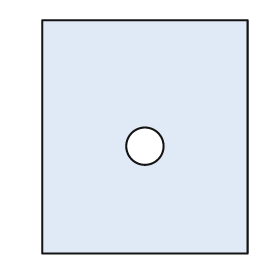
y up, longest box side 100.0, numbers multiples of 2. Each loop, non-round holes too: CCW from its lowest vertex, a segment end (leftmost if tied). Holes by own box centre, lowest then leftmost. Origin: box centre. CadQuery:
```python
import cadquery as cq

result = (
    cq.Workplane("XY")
    .moveTo(-44.0, -50.0)
    .lineTo(44.0, -50.0)
    .lineTo(44.0, 50.0)
    .lineTo(-44.0, 50.0)
    .close()
    .moveTo(0.0, -4.0)
    .circle(8.0)
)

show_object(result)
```